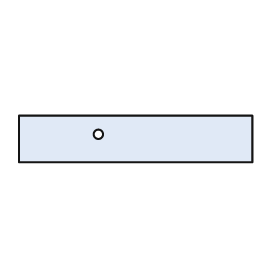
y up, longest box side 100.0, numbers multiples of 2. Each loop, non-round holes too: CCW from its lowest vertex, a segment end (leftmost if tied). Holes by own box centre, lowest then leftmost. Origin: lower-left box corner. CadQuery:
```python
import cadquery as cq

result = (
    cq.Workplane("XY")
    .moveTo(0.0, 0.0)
    .lineTo(100.0, 0.0)
    .lineTo(100.0, 20.0)
    .lineTo(0.0, 20.0)
    .close()
    .moveTo(34.0, 12.0)
    .circle(2.0)
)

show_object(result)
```